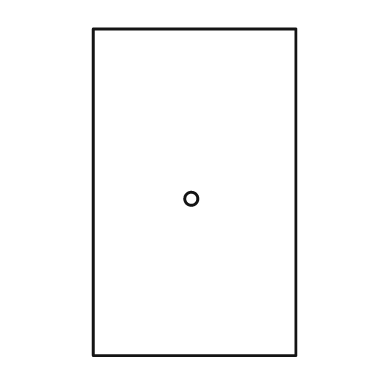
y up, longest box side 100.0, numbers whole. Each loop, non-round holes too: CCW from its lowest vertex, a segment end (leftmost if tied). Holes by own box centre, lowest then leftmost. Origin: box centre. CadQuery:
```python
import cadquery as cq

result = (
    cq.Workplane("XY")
    .moveTo(-31.0, -50.0)
    .lineTo(31.0, -50.0)
    .lineTo(31.0, 50.0)
    .lineTo(-31.0, 50.0)
    .close()
    .moveTo(-1.0, -2.0)
    .circle(2.0)
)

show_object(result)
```